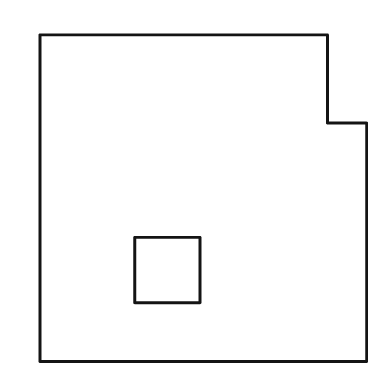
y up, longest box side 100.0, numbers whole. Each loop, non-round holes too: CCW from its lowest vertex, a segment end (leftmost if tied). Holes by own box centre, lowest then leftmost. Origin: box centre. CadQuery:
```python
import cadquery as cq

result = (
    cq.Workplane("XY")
    .moveTo(-50.0, -50.0)
    .lineTo(50.0, -50.0)
    .lineTo(50.0, 23.0)
    .lineTo(38.0, 23.0)
    .lineTo(38.0, 50.0)
    .lineTo(-50.0, 50.0)
    .close()
    .moveTo(-21.0, -32.0)
    .lineTo(-1.0, -32.0)
    .lineTo(-1.0, -12.0)
    .lineTo(-21.0, -12.0)
    .close()
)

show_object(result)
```